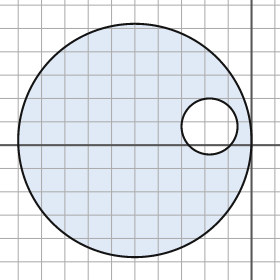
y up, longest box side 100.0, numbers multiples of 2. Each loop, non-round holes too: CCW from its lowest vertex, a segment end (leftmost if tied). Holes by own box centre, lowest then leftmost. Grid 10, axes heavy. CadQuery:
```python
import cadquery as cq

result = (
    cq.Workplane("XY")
    .moveTo(-50.0, 2.0)
    .circle(50.0)
    .moveTo(-18.0, 8.0)
    .circle(12.0)
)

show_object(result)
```